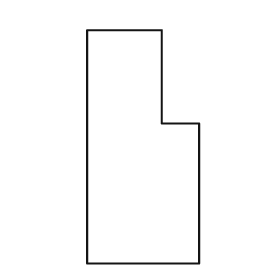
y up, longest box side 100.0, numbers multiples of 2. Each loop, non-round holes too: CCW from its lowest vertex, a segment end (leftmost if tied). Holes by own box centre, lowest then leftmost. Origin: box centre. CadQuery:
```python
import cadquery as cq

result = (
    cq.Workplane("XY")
    .moveTo(-24.0, -50.0)
    .lineTo(24.0, -50.0)
    .lineTo(24.0, 10.0)
    .lineTo(8.0, 10.0)
    .lineTo(8.0, 50.0)
    .lineTo(-24.0, 50.0)
    .close()
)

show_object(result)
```